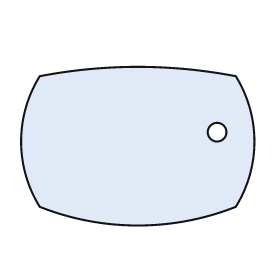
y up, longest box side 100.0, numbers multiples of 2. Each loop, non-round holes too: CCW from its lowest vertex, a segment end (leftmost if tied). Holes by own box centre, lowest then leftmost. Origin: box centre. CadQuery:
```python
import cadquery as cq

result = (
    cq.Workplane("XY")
    .moveTo(-42.0, -26.0)
    .threePointArc((0.0, -34.0), (42.0, -26.0))
    .threePointArc((50.0, 2.0), (42.0, 30.0))
    .threePointArc((0.0, 34.0), (-42.0, 30.0))
    .threePointArc((-50.0, 2.0), (-42.0, -26.0))
    .close()
    .moveTo(34.0, 6.0)
    .circle(4.0)
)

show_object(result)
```